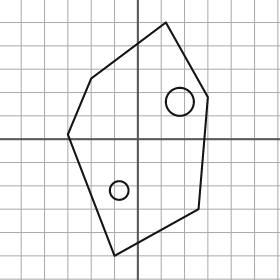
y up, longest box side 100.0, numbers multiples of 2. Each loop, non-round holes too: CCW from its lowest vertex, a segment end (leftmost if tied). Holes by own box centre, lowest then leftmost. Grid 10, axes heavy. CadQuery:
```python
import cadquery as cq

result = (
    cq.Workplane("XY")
    .moveTo(-10.0, -50.0)
    .lineTo(26.0, -30.0)
    .lineTo(30.0, 18.0)
    .lineTo(12.0, 50.0)
    .lineTo(-20.0, 26.0)
    .lineTo(-30.0, 2.0)
    .close()
    .moveTo(-8.0, -22.0)
    .circle(4.0)
    .moveTo(18.0, 16.0)
    .circle(6.0)
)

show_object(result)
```